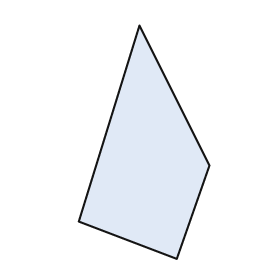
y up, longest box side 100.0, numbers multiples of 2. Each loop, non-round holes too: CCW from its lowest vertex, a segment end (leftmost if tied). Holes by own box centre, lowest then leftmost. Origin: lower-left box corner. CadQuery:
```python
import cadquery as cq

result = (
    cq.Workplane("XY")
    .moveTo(42.0, 0.0)
    .lineTo(56.0, 40.0)
    .lineTo(26.0, 100.0)
    .lineTo(0.0, 16.0)
    .close()
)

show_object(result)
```